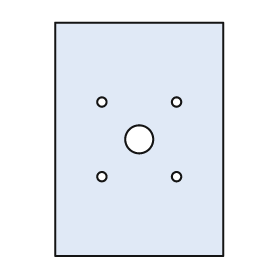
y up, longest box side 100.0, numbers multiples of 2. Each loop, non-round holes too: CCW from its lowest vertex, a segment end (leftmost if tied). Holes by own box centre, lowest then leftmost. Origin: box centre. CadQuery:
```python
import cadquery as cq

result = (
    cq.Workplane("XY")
    .moveTo(-36.0, -50.0)
    .lineTo(36.0, -50.0)
    .lineTo(36.0, 50.0)
    .lineTo(-36.0, 50.0)
    .close()
    .moveTo(-16.0, -16.0)
    .circle(2.0)
    .moveTo(16.0, -16.0)
    .circle(2.0)
    .moveTo(0.0, 0.0)
    .circle(6.0)
    .moveTo(-16.0, 16.0)
    .circle(2.0)
    .moveTo(16.0, 16.0)
    .circle(2.0)
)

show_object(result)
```